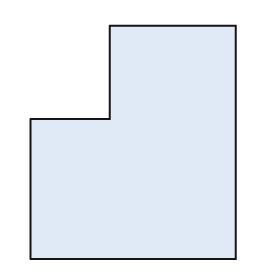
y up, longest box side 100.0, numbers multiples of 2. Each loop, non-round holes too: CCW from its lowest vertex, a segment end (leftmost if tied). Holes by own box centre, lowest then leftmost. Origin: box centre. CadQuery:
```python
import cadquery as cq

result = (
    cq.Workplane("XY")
    .moveTo(-44.0, -50.0)
    .lineTo(44.0, -50.0)
    .lineTo(44.0, 50.0)
    .lineTo(-10.0, 50.0)
    .lineTo(-10.0, 10.0)
    .lineTo(-44.0, 10.0)
    .close()
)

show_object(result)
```